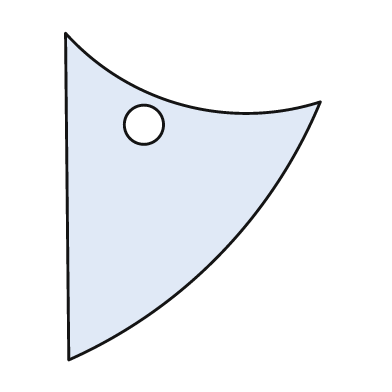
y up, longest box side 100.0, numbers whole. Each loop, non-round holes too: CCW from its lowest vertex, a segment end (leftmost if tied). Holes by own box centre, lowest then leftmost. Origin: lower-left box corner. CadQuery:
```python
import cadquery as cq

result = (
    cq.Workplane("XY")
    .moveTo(1.0, 0.0)
    .threePointArc((47.0, 32.0), (78.0, 79.0))
    .threePointArc((36.0, 78.0), (0.0, 100.0))
    .close()
    .moveTo(24.0, 72.0)
    .circle(6.0)
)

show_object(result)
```